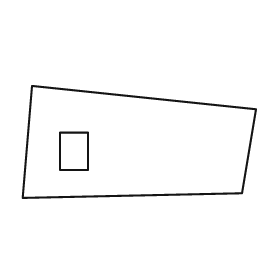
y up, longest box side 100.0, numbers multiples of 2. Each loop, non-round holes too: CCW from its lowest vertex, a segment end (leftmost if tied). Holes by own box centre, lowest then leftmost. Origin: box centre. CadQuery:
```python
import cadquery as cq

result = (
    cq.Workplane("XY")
    .moveTo(-50.0, -24.0)
    .lineTo(44.0, -22.0)
    .lineTo(50.0, 14.0)
    .lineTo(-46.0, 24.0)
    .close()
    .moveTo(-34.0, -12.0)
    .lineTo(-22.0, -12.0)
    .lineTo(-22.0, 4.0)
    .lineTo(-34.0, 4.0)
    .close()
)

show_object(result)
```